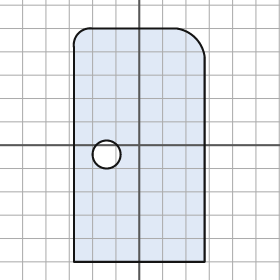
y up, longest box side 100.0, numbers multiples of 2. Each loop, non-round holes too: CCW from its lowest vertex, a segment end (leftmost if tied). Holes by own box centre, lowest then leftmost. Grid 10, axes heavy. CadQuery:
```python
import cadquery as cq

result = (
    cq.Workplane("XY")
    .moveTo(-28.0, -50.0)
    .lineTo(28.0, -50.0)
    .lineTo(28.0, 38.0)
    .threePointArc((24.0, 46.0), (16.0, 50.0))
    .lineTo(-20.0, 50.0)
    .threePointArc((-26.0, 48.0), (-28.0, 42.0))
    .close()
    .moveTo(-14.0, -4.0)
    .circle(6.0)
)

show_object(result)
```